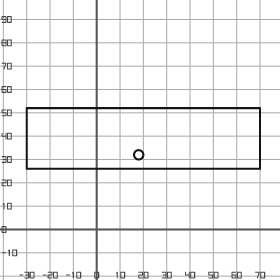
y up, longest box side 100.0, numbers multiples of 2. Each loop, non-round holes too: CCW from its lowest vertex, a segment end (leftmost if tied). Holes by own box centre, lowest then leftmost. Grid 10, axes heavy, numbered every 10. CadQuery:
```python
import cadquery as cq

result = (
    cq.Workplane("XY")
    .moveTo(-30.0, 26.0)
    .lineTo(70.0, 26.0)
    .lineTo(70.0, 52.0)
    .lineTo(-30.0, 52.0)
    .close()
    .moveTo(18.0, 32.0)
    .circle(2.0)
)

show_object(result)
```